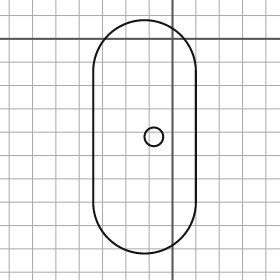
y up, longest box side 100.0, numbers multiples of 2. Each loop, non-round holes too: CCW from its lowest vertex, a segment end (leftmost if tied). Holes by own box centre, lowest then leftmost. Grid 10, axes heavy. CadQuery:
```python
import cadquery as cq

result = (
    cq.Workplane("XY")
    .moveTo(-34.0, -70.0)
    .threePointArc((-12.0, -92.0), (10.0, -70.0))
    .lineTo(10.0, -14.0)
    .threePointArc((-12.0, 8.0), (-34.0, -14.0))
    .close()
    .moveTo(-8.0, -42.0)
    .circle(4.0)
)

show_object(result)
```